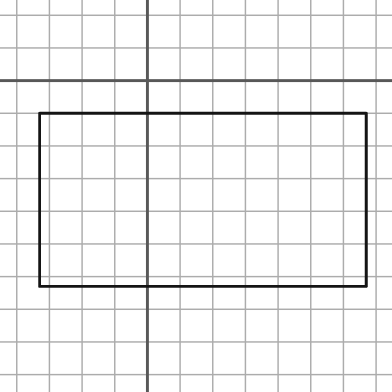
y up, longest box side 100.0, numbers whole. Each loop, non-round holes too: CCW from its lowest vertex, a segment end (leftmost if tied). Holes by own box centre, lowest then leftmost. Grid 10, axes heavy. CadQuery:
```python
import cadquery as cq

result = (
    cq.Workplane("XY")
    .moveTo(-33.0, -63.0)
    .lineTo(67.0, -63.0)
    .lineTo(67.0, -10.0)
    .lineTo(-33.0, -10.0)
    .close()
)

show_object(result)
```